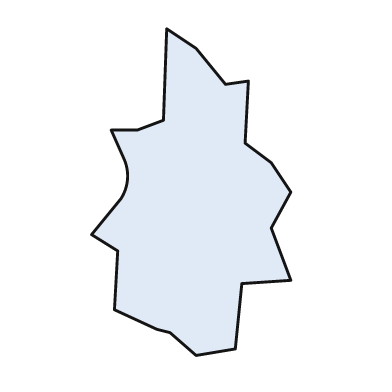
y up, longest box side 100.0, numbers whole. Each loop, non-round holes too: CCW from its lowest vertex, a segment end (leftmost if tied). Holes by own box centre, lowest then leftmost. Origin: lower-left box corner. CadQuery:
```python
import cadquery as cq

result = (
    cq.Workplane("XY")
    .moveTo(32.0, 0.0)
    .lineTo(44.0, 2.0)
    .lineTo(46.0, 22.0)
    .lineTo(61.0, 23.0)
    .lineTo(55.0, 39.0)
    .lineTo(61.0, 50.0)
    .lineTo(55.0, 59.0)
    .lineTo(47.0, 65.0)
    .lineTo(48.0, 84.0)
    .lineTo(41.0, 83.0)
    .lineTo(32.0, 94.0)
    .lineTo(23.0, 100.0)
    .lineTo(22.0, 72.0)
    .lineTo(14.0, 69.0)
    .lineTo(6.0, 69.0)
    .lineTo(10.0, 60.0)
    .threePointArc((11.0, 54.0), (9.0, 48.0))
    .lineTo(0.0, 37.0)
    .lineTo(8.0, 32.0)
    .lineTo(7.0, 14.0)
    .lineTo(20.0, 8.0)
    .lineTo(24.0, 7.0)
    .close()
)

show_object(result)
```